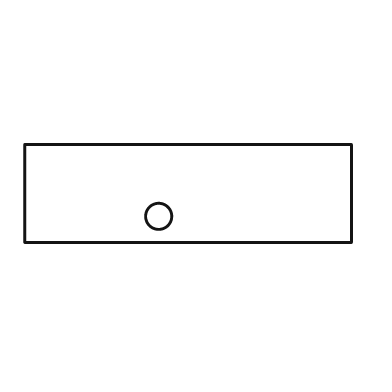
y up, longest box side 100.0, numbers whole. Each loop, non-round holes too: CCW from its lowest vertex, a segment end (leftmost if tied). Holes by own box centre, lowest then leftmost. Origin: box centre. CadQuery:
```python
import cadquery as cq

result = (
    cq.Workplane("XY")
    .moveTo(-50.0, -15.0)
    .lineTo(50.0, -15.0)
    .lineTo(50.0, 15.0)
    .lineTo(-50.0, 15.0)
    .close()
    .moveTo(-9.0, -7.0)
    .circle(4.0)
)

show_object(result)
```